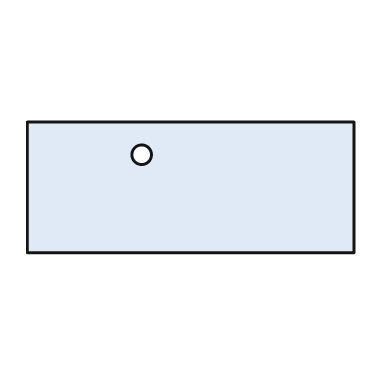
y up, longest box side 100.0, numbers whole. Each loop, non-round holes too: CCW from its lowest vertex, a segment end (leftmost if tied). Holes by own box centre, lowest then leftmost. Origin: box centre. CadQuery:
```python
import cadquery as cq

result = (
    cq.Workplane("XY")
    .moveTo(-50.0, -20.0)
    .lineTo(50.0, -20.0)
    .lineTo(50.0, 20.0)
    .lineTo(-50.0, 20.0)
    .close()
    .moveTo(-15.0, 10.0)
    .circle(3.0)
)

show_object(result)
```